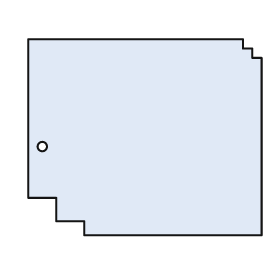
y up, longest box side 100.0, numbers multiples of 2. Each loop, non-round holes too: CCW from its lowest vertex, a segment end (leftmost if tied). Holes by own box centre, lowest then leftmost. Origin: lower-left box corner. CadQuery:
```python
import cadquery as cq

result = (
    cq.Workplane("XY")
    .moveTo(24.0, 0.0)
    .lineTo(100.0, 0.0)
    .lineTo(100.0, 76.0)
    .lineTo(96.0, 76.0)
    .lineTo(96.0, 80.0)
    .lineTo(92.0, 80.0)
    .lineTo(92.0, 84.0)
    .lineTo(0.0, 84.0)
    .lineTo(0.0, 16.0)
    .lineTo(12.0, 16.0)
    .lineTo(12.0, 6.0)
    .lineTo(24.0, 6.0)
    .close()
    .moveTo(6.0, 38.0)
    .circle(2.0)
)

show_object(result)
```